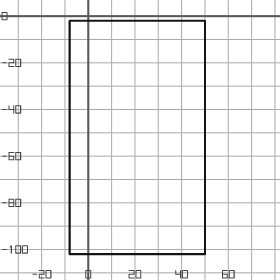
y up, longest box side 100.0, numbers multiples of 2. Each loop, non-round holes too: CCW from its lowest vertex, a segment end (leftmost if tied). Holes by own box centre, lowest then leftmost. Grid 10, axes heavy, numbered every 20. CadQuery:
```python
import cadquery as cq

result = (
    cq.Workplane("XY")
    .moveTo(-8.0, -102.0)
    .lineTo(50.0, -102.0)
    .lineTo(50.0, -2.0)
    .lineTo(-8.0, -2.0)
    .close()
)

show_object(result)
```